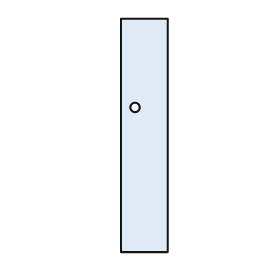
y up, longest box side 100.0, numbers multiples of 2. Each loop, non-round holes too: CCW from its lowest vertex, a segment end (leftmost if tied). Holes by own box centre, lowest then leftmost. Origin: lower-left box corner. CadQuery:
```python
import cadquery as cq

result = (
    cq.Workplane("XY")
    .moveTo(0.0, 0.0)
    .lineTo(20.0, 0.0)
    .lineTo(20.0, 100.0)
    .lineTo(0.0, 100.0)
    .close()
    .moveTo(6.0, 62.0)
    .circle(2.0)
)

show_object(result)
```